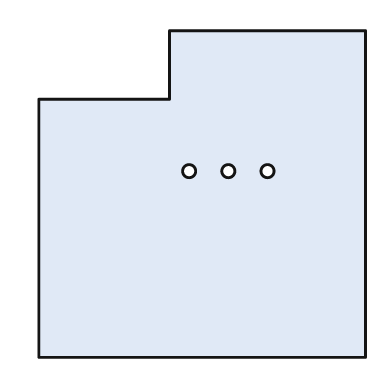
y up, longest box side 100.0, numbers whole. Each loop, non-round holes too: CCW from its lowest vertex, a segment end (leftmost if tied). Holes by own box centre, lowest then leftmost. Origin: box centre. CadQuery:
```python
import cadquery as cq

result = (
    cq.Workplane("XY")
    .moveTo(-50.0, -50.0)
    .lineTo(50.0, -50.0)
    .lineTo(50.0, 50.0)
    .lineTo(-10.0, 50.0)
    .lineTo(-10.0, 29.0)
    .lineTo(-50.0, 29.0)
    .close()
    .moveTo(-4.0, 7.0)
    .circle(2.0)
    .moveTo(8.0, 7.0)
    .circle(2.0)
    .moveTo(20.0, 7.0)
    .circle(2.0)
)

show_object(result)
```